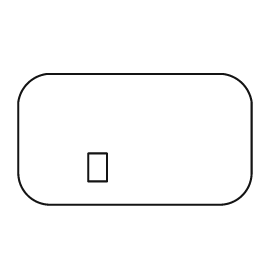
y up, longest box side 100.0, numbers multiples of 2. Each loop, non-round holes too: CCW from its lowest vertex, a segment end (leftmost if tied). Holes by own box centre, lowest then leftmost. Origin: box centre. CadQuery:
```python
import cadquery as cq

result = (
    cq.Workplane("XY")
    .moveTo(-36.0, -28.0)
    .lineTo(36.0, -28.0)
    .threePointArc((46.0, -24.0), (50.0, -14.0))
    .lineTo(50.0, 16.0)
    .threePointArc((46.0, 24.0), (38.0, 28.0))
    .lineTo(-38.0, 28.0)
    .threePointArc((-46.0, 24.0), (-50.0, 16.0))
    .lineTo(-50.0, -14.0)
    .threePointArc((-46.0, -24.0), (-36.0, -28.0))
    .close()
    .moveTo(-20.0, -18.0)
    .lineTo(-12.0, -18.0)
    .lineTo(-12.0, -6.0)
    .lineTo(-20.0, -6.0)
    .close()
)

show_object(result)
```